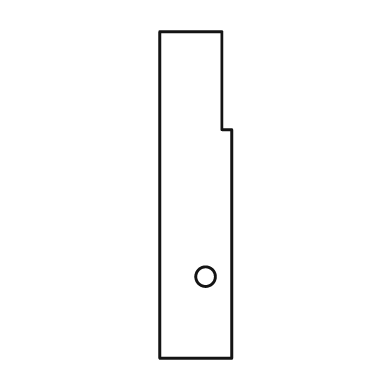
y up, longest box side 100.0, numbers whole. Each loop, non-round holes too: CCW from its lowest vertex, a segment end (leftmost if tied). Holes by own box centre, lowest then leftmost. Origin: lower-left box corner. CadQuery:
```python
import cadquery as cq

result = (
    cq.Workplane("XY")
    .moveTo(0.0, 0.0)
    .lineTo(22.0, 0.0)
    .lineTo(22.0, 70.0)
    .lineTo(19.0, 70.0)
    .lineTo(19.0, 100.0)
    .lineTo(0.0, 100.0)
    .close()
    .moveTo(14.0, 25.0)
    .circle(3.0)
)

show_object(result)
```